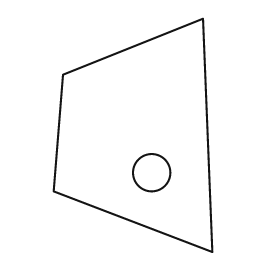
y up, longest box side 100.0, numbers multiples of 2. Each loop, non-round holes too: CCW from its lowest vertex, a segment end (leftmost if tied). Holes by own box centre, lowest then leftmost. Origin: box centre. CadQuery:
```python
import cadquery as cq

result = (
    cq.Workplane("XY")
    .moveTo(34.0, -50.0)
    .lineTo(30.0, 50.0)
    .lineTo(-30.0, 26.0)
    .lineTo(-34.0, -24.0)
    .close()
    .moveTo(8.0, -16.0)
    .circle(8.0)
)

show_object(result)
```